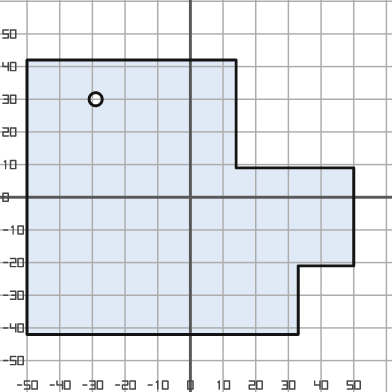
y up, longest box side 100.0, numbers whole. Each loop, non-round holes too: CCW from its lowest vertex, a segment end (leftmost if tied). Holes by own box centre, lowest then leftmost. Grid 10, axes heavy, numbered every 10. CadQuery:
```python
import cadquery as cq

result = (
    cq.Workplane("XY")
    .moveTo(-50.0, -42.0)
    .lineTo(33.0, -42.0)
    .lineTo(33.0, -21.0)
    .lineTo(50.0, -21.0)
    .lineTo(50.0, 9.0)
    .lineTo(14.0, 9.0)
    .lineTo(14.0, 42.0)
    .lineTo(-50.0, 42.0)
    .close()
    .moveTo(-29.0, 30.0)
    .circle(2.0)
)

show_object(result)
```